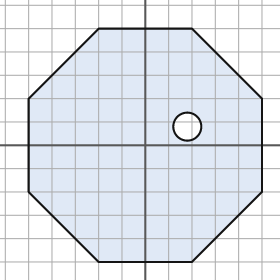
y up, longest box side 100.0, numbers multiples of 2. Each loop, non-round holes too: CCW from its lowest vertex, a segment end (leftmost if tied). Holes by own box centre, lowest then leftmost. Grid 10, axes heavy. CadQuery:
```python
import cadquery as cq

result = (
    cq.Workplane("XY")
    .moveTo(-20.0, -50.0)
    .lineTo(20.0, -50.0)
    .lineTo(50.0, -20.0)
    .lineTo(50.0, 20.0)
    .lineTo(20.0, 50.0)
    .lineTo(-20.0, 50.0)
    .lineTo(-50.0, 20.0)
    .lineTo(-50.0, -20.0)
    .close()
    .moveTo(18.0, 8.0)
    .circle(6.0)
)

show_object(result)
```